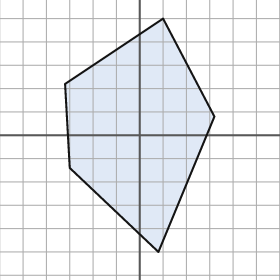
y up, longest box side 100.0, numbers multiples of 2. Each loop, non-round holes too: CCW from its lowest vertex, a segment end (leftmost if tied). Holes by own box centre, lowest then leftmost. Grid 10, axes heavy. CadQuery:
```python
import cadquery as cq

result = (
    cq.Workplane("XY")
    .moveTo(8.0, -50.0)
    .lineTo(32.0, 8.0)
    .lineTo(10.0, 50.0)
    .lineTo(-32.0, 22.0)
    .lineTo(-30.0, -14.0)
    .close()
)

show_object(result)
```